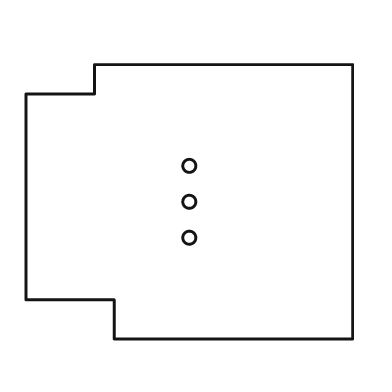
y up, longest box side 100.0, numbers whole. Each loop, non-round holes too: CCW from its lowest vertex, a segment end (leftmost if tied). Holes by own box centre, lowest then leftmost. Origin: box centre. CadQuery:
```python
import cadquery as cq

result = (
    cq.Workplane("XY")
    .moveTo(-23.0, -42.0)
    .lineTo(50.0, -42.0)
    .lineTo(50.0, 42.0)
    .lineTo(-29.0, 42.0)
    .lineTo(-29.0, 33.0)
    .lineTo(-50.0, 33.0)
    .lineTo(-50.0, -30.0)
    .lineTo(-23.0, -30.0)
    .close()
    .moveTo(0.0, -11.0)
    .circle(2.0)
    .moveTo(0.0, 0.0)
    .circle(2.0)
    .moveTo(0.0, 11.0)
    .circle(2.0)
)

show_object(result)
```